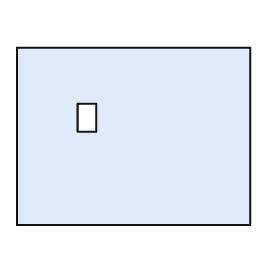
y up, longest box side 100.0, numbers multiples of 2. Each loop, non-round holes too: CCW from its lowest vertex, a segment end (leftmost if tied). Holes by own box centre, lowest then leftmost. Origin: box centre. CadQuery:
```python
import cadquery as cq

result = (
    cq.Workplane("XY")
    .moveTo(-50.0, -38.0)
    .lineTo(50.0, -38.0)
    .lineTo(50.0, 38.0)
    .lineTo(-50.0, 38.0)
    .close()
    .moveTo(-24.0, 2.0)
    .lineTo(-16.0, 2.0)
    .lineTo(-16.0, 14.0)
    .lineTo(-24.0, 14.0)
    .close()
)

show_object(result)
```